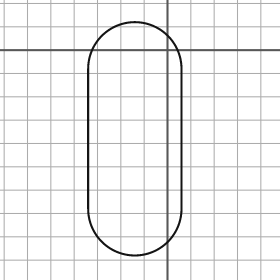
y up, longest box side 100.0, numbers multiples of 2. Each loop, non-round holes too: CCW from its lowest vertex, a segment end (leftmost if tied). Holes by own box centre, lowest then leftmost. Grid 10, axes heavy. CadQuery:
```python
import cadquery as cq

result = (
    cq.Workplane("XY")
    .moveTo(-34.0, -68.0)
    .threePointArc((-14.0, -88.0), (6.0, -68.0))
    .lineTo(6.0, -8.0)
    .threePointArc((-14.0, 12.0), (-34.0, -8.0))
    .close()
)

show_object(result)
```